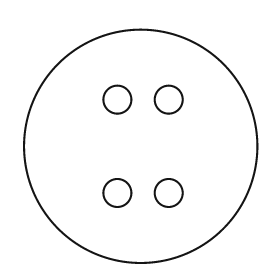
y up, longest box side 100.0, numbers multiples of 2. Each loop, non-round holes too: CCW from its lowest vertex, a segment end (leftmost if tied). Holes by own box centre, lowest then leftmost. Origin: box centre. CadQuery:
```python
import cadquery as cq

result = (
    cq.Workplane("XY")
    .moveTo(0.0, 0.0)
    .circle(50.0)
    .moveTo(-10.0, -20.0)
    .circle(6.0)
    .moveTo(12.0, -20.0)
    .circle(6.0)
    .moveTo(-10.0, 20.0)
    .circle(6.0)
    .moveTo(12.0, 20.0)
    .circle(6.0)
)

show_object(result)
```